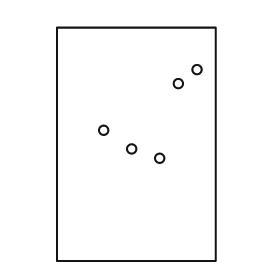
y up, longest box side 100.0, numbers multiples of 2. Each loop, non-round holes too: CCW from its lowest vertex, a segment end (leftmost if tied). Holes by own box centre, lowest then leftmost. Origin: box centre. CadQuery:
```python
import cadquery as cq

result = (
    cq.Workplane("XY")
    .moveTo(-34.0, -50.0)
    .lineTo(34.0, -50.0)
    .lineTo(34.0, 50.0)
    .lineTo(-34.0, 50.0)
    .close()
    .moveTo(10.0, -6.0)
    .circle(2.0)
    .moveTo(-2.0, -2.0)
    .circle(2.0)
    .moveTo(-14.0, 6.0)
    .circle(2.0)
    .moveTo(18.0, 26.0)
    .circle(2.0)
    .moveTo(26.0, 32.0)
    .circle(2.0)
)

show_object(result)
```